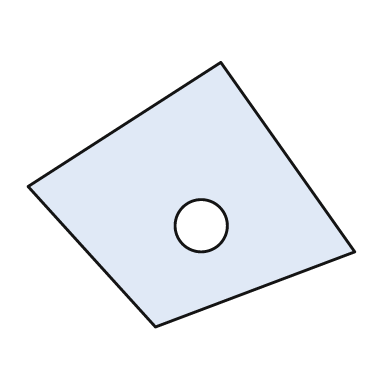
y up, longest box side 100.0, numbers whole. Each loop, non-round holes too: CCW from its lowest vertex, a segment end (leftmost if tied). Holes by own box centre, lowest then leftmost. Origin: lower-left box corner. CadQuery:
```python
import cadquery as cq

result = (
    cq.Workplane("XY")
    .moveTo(39.0, 0.0)
    .lineTo(100.0, 23.0)
    .lineTo(59.0, 81.0)
    .lineTo(0.0, 43.0)
    .close()
    .moveTo(53.0, 31.0)
    .circle(8.0)
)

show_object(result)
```